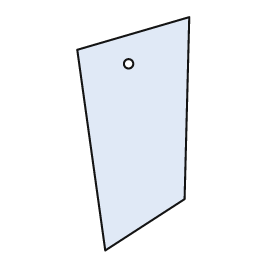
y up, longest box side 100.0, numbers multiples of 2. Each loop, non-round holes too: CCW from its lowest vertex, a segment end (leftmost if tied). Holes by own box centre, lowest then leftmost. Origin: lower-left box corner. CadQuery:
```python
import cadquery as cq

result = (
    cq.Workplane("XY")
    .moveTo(12.0, 0.0)
    .lineTo(46.0, 22.0)
    .lineTo(48.0, 100.0)
    .lineTo(0.0, 86.0)
    .close()
    .moveTo(22.0, 80.0)
    .circle(2.0)
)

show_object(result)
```